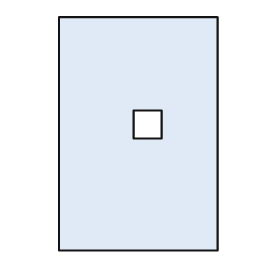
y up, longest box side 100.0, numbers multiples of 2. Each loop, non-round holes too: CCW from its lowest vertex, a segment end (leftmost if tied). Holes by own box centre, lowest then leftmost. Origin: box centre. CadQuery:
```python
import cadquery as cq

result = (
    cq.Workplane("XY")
    .moveTo(-34.0, -50.0)
    .lineTo(34.0, -50.0)
    .lineTo(34.0, 50.0)
    .lineTo(-34.0, 50.0)
    .close()
    .moveTo(-2.0, -2.0)
    .lineTo(10.0, -2.0)
    .lineTo(10.0, 10.0)
    .lineTo(-2.0, 10.0)
    .close()
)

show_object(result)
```